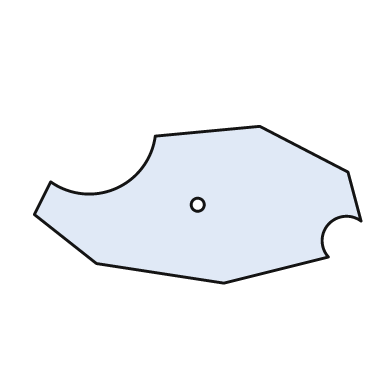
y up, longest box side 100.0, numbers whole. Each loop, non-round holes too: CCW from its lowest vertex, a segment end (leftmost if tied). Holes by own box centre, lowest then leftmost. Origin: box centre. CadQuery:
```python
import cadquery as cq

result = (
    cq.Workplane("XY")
    .moveTo(8.0, -24.0)
    .lineTo(40.0, -16.0)
    .threePointArc((40.0, -6.0), (50.0, -5.0))
    .lineTo(46.0, 10.0)
    .lineTo(19.0, 24.0)
    .lineTo(-13.0, 21.0)
    .threePointArc((-25.0, 5.0), (-45.0, 7.0))
    .lineTo(-50.0, -3.0)
    .lineTo(-31.0, -18.0)
    .close()
    .moveTo(0.0, 0.0)
    .circle(2.0)
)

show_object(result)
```